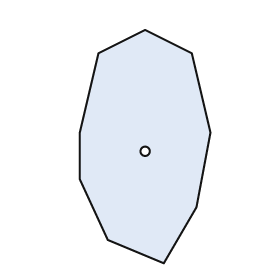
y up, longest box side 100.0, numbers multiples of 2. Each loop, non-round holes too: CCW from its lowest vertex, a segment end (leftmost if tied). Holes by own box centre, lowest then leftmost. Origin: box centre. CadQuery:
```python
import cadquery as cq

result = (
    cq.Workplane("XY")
    .moveTo(8.0, -50.0)
    .lineTo(22.0, -26.0)
    .lineTo(28.0, 6.0)
    .lineTo(20.0, 40.0)
    .lineTo(0.0, 50.0)
    .lineTo(-20.0, 40.0)
    .lineTo(-28.0, 6.0)
    .lineTo(-28.0, -14.0)
    .lineTo(-16.0, -40.0)
    .close()
    .moveTo(0.0, -2.0)
    .circle(2.0)
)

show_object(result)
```